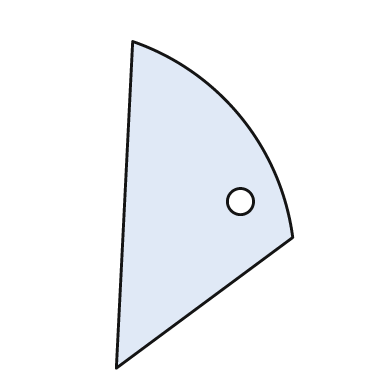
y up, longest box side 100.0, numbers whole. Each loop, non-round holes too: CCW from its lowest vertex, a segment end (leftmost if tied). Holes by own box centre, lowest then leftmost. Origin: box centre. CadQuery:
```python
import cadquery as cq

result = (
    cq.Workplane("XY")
    .moveTo(-27.0, -50.0)
    .lineTo(27.0, -10.0)
    .threePointArc((11.0, 27.0), (-22.0, 50.0))
    .close()
    .moveTo(11.0, 1.0)
    .circle(4.0)
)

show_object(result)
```